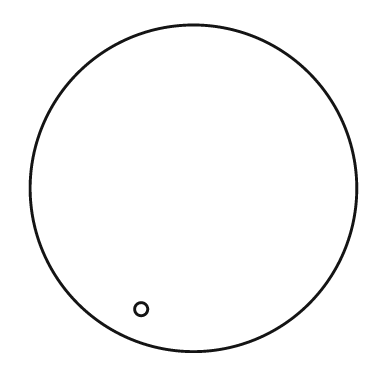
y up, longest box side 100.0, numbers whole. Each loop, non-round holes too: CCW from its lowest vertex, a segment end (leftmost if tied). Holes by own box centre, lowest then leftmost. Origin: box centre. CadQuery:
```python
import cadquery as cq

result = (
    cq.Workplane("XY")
    .moveTo(0.0, 0.0)
    .circle(50.0)
    .moveTo(-16.0, -37.0)
    .circle(2.0)
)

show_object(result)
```